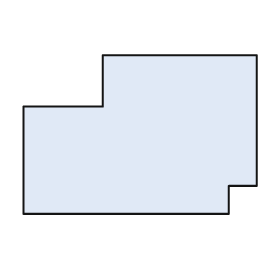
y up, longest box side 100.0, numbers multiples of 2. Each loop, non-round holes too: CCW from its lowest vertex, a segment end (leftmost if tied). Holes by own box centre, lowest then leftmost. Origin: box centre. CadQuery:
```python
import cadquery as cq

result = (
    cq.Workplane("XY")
    .moveTo(-50.0, -34.0)
    .lineTo(38.0, -34.0)
    .lineTo(38.0, -22.0)
    .lineTo(50.0, -22.0)
    .lineTo(50.0, 34.0)
    .lineTo(-16.0, 34.0)
    .lineTo(-16.0, 12.0)
    .lineTo(-50.0, 12.0)
    .close()
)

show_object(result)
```